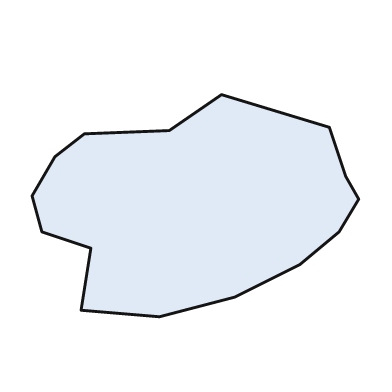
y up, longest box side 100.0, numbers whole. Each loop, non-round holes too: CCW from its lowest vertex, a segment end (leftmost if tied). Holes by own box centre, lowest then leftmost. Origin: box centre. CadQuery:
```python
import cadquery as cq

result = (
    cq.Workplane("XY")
    .moveTo(-11.0, -34.0)
    .lineTo(12.0, -28.0)
    .lineTo(32.0, -18.0)
    .lineTo(44.0, -8.0)
    .lineTo(50.0, 2.0)
    .lineTo(46.0, 9.0)
    .lineTo(41.0, 24.0)
    .lineTo(8.0, 34.0)
    .lineTo(-8.0, 23.0)
    .lineTo(-34.0, 22.0)
    .lineTo(-43.0, 15.0)
    .lineTo(-50.0, 3.0)
    .lineTo(-47.0, -8.0)
    .lineTo(-32.0, -13.0)
    .lineTo(-35.0, -32.0)
    .close()
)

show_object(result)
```